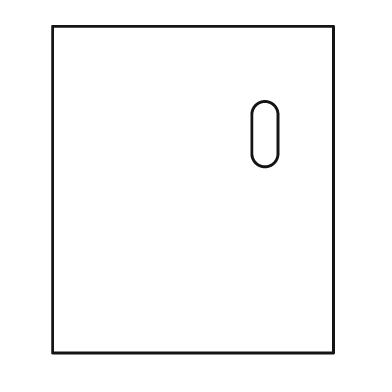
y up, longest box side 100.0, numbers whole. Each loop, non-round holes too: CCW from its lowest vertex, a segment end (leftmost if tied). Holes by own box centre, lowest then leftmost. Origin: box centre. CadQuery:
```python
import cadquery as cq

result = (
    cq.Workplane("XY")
    .moveTo(-43.0, -50.0)
    .lineTo(43.0, -50.0)
    .lineTo(43.0, 50.0)
    .lineTo(-43.0, 50.0)
    .close()
    .moveTo(18.0, 11.0)
    .threePointArc((22.0, 7.0), (26.0, 11.0))
    .lineTo(26.0, 23.0)
    .threePointArc((22.0, 27.0), (18.0, 23.0))
    .close()
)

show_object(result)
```